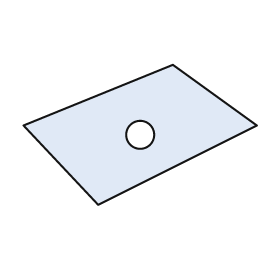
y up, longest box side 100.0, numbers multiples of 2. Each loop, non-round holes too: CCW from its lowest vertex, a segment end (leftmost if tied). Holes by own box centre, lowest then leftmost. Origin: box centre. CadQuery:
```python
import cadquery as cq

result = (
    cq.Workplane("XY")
    .moveTo(-18.0, -30.0)
    .lineTo(50.0, 4.0)
    .lineTo(14.0, 30.0)
    .lineTo(-50.0, 4.0)
    .close()
    .moveTo(0.0, 0.0)
    .circle(6.0)
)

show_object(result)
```